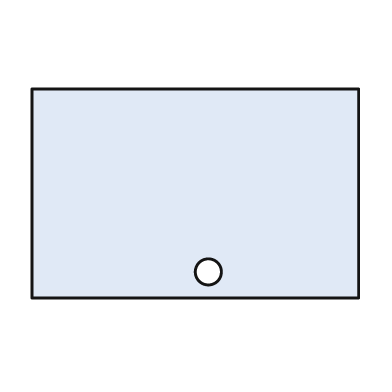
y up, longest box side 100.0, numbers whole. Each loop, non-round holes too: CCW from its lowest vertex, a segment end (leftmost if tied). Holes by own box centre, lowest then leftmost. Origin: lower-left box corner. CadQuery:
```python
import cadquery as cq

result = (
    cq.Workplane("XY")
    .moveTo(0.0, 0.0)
    .lineTo(100.0, 0.0)
    .lineTo(100.0, 64.0)
    .lineTo(0.0, 64.0)
    .close()
    .moveTo(54.0, 8.0)
    .circle(4.0)
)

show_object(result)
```